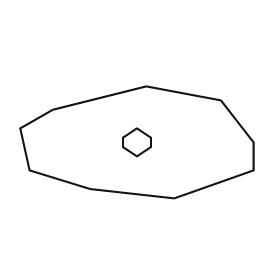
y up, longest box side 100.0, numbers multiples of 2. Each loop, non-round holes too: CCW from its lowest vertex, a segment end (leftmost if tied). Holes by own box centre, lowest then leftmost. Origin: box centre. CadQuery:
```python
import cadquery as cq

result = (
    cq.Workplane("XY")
    .moveTo(16.0, -24.0)
    .lineTo(50.0, -12.0)
    .lineTo(50.0, 0.0)
    .lineTo(36.0, 18.0)
    .lineTo(4.0, 24.0)
    .lineTo(-36.0, 14.0)
    .lineTo(-50.0, 6.0)
    .lineTo(-46.0, -12.0)
    .lineTo(-20.0, -20.0)
    .close()
    .moveTo(0.0, -6.0)
    .lineTo(6.0, -2.0)
    .lineTo(6.0, 2.0)
    .lineTo(0.0, 6.0)
    .lineTo(-6.0, 2.0)
    .lineTo(-6.0, -2.0)
    .close()
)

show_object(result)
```